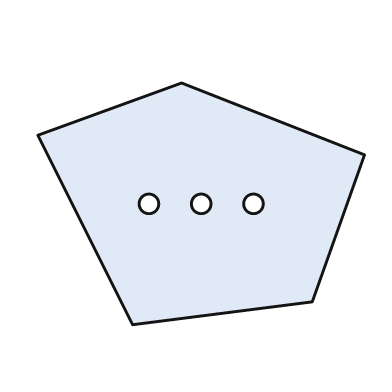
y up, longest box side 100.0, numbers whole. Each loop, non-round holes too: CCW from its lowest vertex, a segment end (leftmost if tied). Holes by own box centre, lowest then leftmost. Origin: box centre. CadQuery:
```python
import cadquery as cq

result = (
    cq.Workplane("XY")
    .moveTo(-21.0, -37.0)
    .lineTo(34.0, -30.0)
    .lineTo(50.0, 15.0)
    .lineTo(-6.0, 37.0)
    .lineTo(-50.0, 21.0)
    .close()
    .moveTo(-16.0, 0.0)
    .circle(3.0)
    .moveTo(0.0, 0.0)
    .circle(3.0)
    .moveTo(16.0, 0.0)
    .circle(3.0)
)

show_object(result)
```